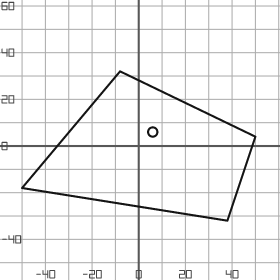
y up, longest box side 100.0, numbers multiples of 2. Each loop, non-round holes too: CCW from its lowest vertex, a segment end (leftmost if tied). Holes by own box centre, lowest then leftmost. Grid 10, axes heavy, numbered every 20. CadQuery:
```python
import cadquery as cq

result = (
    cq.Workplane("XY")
    .moveTo(38.0, -32.0)
    .lineTo(50.0, 4.0)
    .lineTo(-8.0, 32.0)
    .lineTo(-50.0, -18.0)
    .close()
    .moveTo(6.0, 6.0)
    .circle(2.0)
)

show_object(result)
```